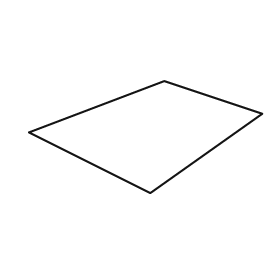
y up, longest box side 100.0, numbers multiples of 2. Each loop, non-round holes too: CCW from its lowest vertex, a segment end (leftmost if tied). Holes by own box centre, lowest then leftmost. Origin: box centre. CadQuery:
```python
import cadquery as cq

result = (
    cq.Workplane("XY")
    .moveTo(2.0, -24.0)
    .lineTo(50.0, 10.0)
    .lineTo(8.0, 24.0)
    .lineTo(-50.0, 2.0)
    .close()
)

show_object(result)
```